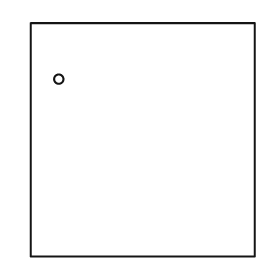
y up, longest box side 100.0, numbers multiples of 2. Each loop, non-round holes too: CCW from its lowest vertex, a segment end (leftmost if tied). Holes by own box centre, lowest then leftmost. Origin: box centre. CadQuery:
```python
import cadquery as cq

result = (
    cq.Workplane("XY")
    .moveTo(-48.0, -50.0)
    .lineTo(48.0, -50.0)
    .lineTo(48.0, 50.0)
    .lineTo(-48.0, 50.0)
    .close()
    .moveTo(-36.0, 26.0)
    .circle(2.0)
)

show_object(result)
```